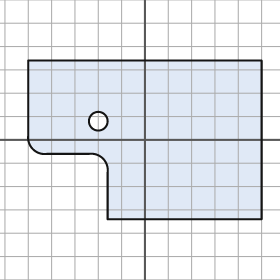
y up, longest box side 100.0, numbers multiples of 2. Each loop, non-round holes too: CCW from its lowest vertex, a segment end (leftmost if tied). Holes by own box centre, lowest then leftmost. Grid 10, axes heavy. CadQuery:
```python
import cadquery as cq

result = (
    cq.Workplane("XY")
    .moveTo(-16.0, -34.0)
    .lineTo(50.0, -34.0)
    .lineTo(50.0, 34.0)
    .lineTo(-50.0, 34.0)
    .lineTo(-50.0, 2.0)
    .threePointArc((-48.0, -4.0), (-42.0, -6.0))
    .lineTo(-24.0, -6.0)
    .threePointArc((-18.0, -8.0), (-16.0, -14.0))
    .close()
    .moveTo(-20.0, 8.0)
    .circle(4.0)
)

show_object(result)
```